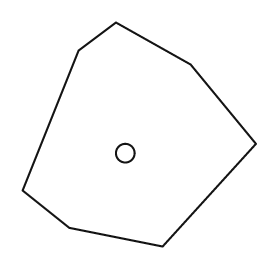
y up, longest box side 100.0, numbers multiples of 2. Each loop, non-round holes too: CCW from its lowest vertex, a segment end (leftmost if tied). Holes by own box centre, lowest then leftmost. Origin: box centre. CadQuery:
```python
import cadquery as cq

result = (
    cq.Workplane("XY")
    .moveTo(10.0, -48.0)
    .lineTo(50.0, -4.0)
    .lineTo(22.0, 30.0)
    .lineTo(-10.0, 48.0)
    .lineTo(-26.0, 36.0)
    .lineTo(-50.0, -24.0)
    .lineTo(-30.0, -40.0)
    .close()
    .moveTo(-6.0, -8.0)
    .circle(4.0)
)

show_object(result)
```